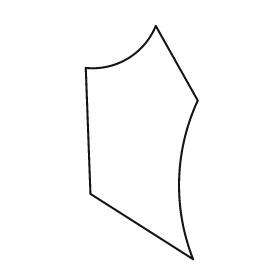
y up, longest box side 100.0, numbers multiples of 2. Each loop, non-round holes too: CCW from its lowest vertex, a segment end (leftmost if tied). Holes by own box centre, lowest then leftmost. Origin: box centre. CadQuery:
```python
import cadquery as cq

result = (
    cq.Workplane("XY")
    .moveTo(22.0, -50.0)
    .threePointArc((16.0, -16.0), (24.0, 18.0))
    .lineTo(6.0, 50.0)
    .threePointArc((-6.0, 36.0), (-24.0, 32.0))
    .lineTo(-22.0, -22.0)
    .close()
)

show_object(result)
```